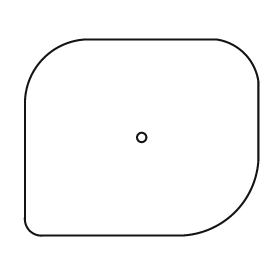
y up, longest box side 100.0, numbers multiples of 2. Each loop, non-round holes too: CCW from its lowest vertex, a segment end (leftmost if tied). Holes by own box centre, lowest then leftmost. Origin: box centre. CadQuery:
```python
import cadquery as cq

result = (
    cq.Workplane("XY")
    .moveTo(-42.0, -42.0)
    .lineTo(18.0, -42.0)
    .threePointArc((40.0, -32.0), (50.0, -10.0))
    .lineTo(50.0, 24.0)
    .threePointArc((44.0, 36.0), (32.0, 42.0))
    .lineTo(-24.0, 42.0)
    .threePointArc((-42.0, 34.0), (-50.0, 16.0))
    .lineTo(-50.0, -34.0)
    .threePointArc((-48.0, -40.0), (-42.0, -42.0))
    .close()
    .moveTo(0.0, 0.0)
    .circle(2.0)
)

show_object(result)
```